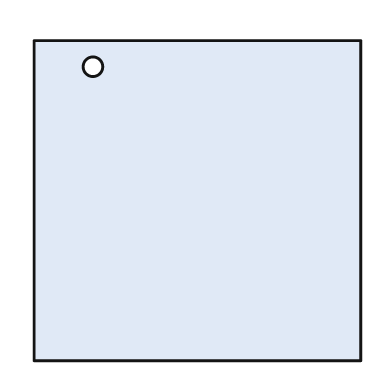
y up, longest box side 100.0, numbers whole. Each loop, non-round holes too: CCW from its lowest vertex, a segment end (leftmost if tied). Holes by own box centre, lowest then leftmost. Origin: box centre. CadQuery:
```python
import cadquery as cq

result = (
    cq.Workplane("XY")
    .moveTo(-50.0, -49.0)
    .lineTo(50.0, -49.0)
    .lineTo(50.0, 49.0)
    .lineTo(-50.0, 49.0)
    .close()
    .moveTo(-32.0, 41.0)
    .circle(3.0)
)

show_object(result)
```